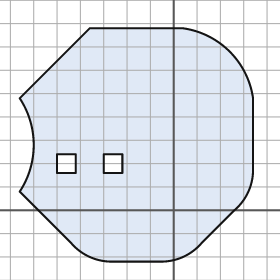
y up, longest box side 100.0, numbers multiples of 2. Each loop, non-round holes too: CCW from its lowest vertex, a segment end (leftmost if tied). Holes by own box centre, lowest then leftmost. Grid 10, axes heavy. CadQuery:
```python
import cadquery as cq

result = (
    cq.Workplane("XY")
    .moveTo(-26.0, -22.0)
    .lineTo(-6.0, -22.0)
    .threePointArc((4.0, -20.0), (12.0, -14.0))
    .lineTo(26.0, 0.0)
    .threePointArc((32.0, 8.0), (34.0, 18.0))
    .lineTo(34.0, 48.0)
    .threePointArc((24.0, 68.0), (4.0, 78.0))
    .lineTo(-36.0, 78.0)
    .lineTo(-66.0, 48.0)
    .threePointArc((-60.0, 28.0), (-66.0, 8.0))
    .lineTo(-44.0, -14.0)
    .threePointArc((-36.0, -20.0), (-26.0, -22.0))
    .close()
    .moveTo(-50.0, 16.0)
    .lineTo(-42.0, 16.0)
    .lineTo(-42.0, 24.0)
    .lineTo(-50.0, 24.0)
    .close()
    .moveTo(-30.0, 16.0)
    .lineTo(-22.0, 16.0)
    .lineTo(-22.0, 24.0)
    .lineTo(-30.0, 24.0)
    .close()
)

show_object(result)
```